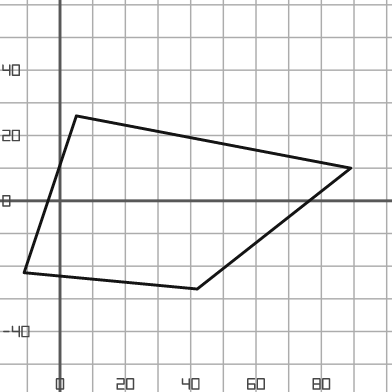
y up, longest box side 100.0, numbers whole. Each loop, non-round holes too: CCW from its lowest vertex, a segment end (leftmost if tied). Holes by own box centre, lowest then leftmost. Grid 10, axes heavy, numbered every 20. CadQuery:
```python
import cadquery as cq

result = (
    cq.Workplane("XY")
    .moveTo(42.0, -27.0)
    .lineTo(89.0, 10.0)
    .lineTo(5.0, 26.0)
    .lineTo(-11.0, -22.0)
    .close()
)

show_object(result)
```